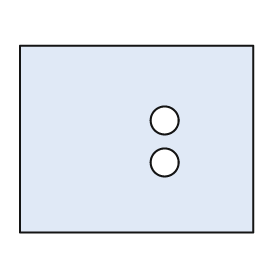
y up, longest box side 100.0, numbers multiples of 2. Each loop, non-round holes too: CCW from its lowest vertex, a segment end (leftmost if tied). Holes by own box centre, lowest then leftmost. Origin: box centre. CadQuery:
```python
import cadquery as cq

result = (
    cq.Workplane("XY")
    .moveTo(-50.0, -40.0)
    .lineTo(50.0, -40.0)
    .lineTo(50.0, 40.0)
    .lineTo(-50.0, 40.0)
    .close()
    .moveTo(12.0, -10.0)
    .circle(6.0)
    .moveTo(12.0, 8.0)
    .circle(6.0)
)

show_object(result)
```